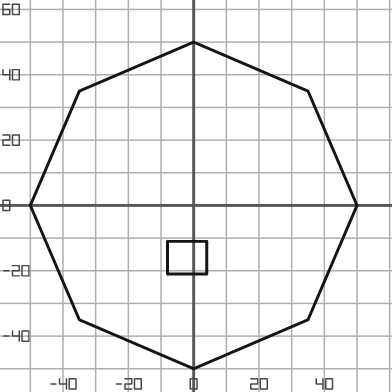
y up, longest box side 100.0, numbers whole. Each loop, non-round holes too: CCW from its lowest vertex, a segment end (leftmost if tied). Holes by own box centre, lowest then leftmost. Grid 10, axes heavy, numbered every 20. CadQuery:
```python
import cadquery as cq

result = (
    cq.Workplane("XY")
    .moveTo(0.0, -50.0)
    .lineTo(35.0, -35.0)
    .lineTo(50.0, 0.0)
    .lineTo(35.0, 35.0)
    .lineTo(0.0, 50.0)
    .lineTo(-35.0, 35.0)
    .lineTo(-50.0, 0.0)
    .lineTo(-35.0, -35.0)
    .close()
    .moveTo(-8.0, -21.0)
    .lineTo(4.0, -21.0)
    .lineTo(4.0, -11.0)
    .lineTo(-8.0, -11.0)
    .close()
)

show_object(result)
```